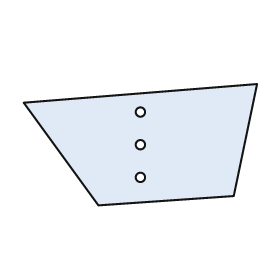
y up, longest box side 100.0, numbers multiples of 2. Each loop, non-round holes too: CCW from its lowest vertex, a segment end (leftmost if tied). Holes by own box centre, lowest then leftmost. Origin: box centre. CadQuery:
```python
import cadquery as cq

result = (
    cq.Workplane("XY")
    .moveTo(-18.0, -26.0)
    .lineTo(40.0, -22.0)
    .lineTo(50.0, 26.0)
    .lineTo(-50.0, 18.0)
    .close()
    .moveTo(0.0, -14.0)
    .circle(2.0)
    .moveTo(0.0, 0.0)
    .circle(2.0)
    .moveTo(0.0, 14.0)
    .circle(2.0)
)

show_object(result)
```